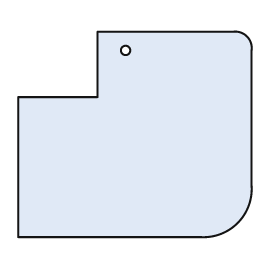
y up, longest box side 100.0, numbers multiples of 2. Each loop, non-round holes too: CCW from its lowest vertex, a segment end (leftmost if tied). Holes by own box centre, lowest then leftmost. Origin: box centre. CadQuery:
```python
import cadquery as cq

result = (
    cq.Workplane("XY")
    .moveTo(-50.0, -44.0)
    .lineTo(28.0, -44.0)
    .threePointArc((44.0, -38.0), (50.0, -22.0))
    .lineTo(50.0, 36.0)
    .threePointArc((48.0, 42.0), (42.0, 44.0))
    .lineTo(-16.0, 44.0)
    .lineTo(-16.0, 16.0)
    .lineTo(-50.0, 16.0)
    .close()
    .moveTo(-4.0, 36.0)
    .circle(2.0)
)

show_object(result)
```